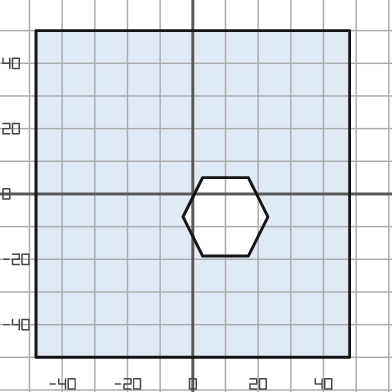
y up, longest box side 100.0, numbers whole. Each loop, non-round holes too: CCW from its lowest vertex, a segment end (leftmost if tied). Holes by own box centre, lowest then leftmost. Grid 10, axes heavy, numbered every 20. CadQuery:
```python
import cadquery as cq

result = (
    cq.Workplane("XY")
    .moveTo(-48.0, -50.0)
    .lineTo(48.0, -50.0)
    .lineTo(48.0, 50.0)
    .lineTo(-48.0, 50.0)
    .close()
    .moveTo(3.0, -19.0)
    .lineTo(17.0, -19.0)
    .lineTo(23.0, -7.0)
    .lineTo(17.0, 5.0)
    .lineTo(3.0, 5.0)
    .lineTo(-3.0, -7.0)
    .close()
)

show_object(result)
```